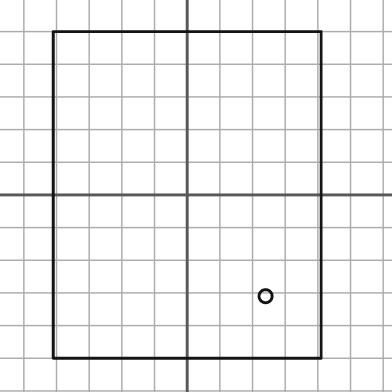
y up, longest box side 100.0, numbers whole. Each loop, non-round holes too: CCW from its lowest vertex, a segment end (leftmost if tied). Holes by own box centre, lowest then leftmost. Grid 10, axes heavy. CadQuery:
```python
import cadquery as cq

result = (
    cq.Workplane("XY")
    .moveTo(-41.0, -50.0)
    .lineTo(41.0, -50.0)
    .lineTo(41.0, 50.0)
    .lineTo(-41.0, 50.0)
    .close()
    .moveTo(24.0, -31.0)
    .circle(2.0)
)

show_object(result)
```